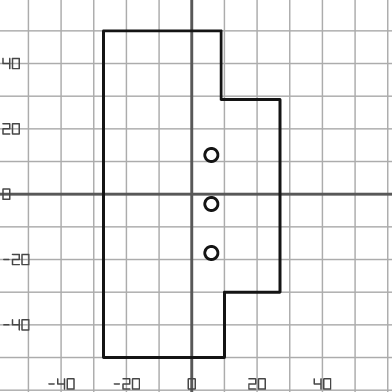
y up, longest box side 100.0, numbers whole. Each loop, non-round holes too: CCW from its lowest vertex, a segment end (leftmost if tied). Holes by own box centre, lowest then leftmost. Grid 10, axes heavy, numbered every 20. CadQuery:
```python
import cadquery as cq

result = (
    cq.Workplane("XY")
    .moveTo(-27.0, -50.0)
    .lineTo(10.0, -50.0)
    .lineTo(10.0, -30.0)
    .lineTo(27.0, -30.0)
    .lineTo(27.0, 29.0)
    .lineTo(9.0, 29.0)
    .lineTo(9.0, 50.0)
    .lineTo(-27.0, 50.0)
    .close()
    .moveTo(6.0, -18.0)
    .circle(2.0)
    .moveTo(6.0, -3.0)
    .circle(2.0)
    .moveTo(6.0, 12.0)
    .circle(2.0)
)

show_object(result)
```